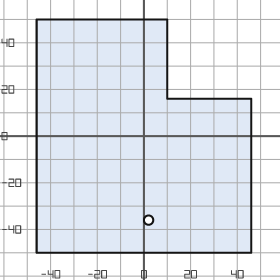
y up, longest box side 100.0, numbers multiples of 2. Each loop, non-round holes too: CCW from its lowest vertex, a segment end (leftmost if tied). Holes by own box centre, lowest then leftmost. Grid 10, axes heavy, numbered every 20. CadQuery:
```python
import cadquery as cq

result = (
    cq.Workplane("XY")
    .moveTo(-46.0, -50.0)
    .lineTo(46.0, -50.0)
    .lineTo(46.0, 16.0)
    .lineTo(10.0, 16.0)
    .lineTo(10.0, 50.0)
    .lineTo(-46.0, 50.0)
    .close()
    .moveTo(2.0, -36.0)
    .circle(2.0)
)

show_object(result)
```